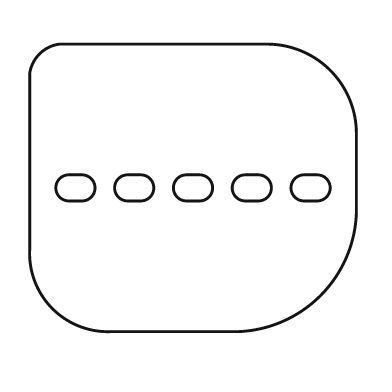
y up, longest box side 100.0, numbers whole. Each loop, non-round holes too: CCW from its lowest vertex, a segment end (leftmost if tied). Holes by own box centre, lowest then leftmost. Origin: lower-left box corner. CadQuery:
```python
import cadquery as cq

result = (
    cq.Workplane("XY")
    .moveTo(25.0, 0.0)
    .lineTo(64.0, 0.0)
    .threePointArc((89.0, 11.0), (100.0, 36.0))
    .lineTo(100.0, 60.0)
    .threePointArc((92.0, 80.0), (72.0, 88.0))
    .lineTo(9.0, 88.0)
    .threePointArc((3.0, 85.0), (0.0, 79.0))
    .lineTo(0.0, 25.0)
    .threePointArc((7.0, 7.0), (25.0, 0.0))
    .close()
    .moveTo(12.0, 40.0)
    .lineTo(16.0, 40.0)
    .threePointArc((20.0, 44.0), (16.0, 48.0))
    .lineTo(12.0, 48.0)
    .threePointArc((8.0, 44.0), (12.0, 40.0))
    .close()
    .moveTo(30.0, 40.0)
    .lineTo(34.0, 40.0)
    .threePointArc((38.0, 44.0), (34.0, 48.0))
    .lineTo(30.0, 48.0)
    .threePointArc((26.0, 44.0), (30.0, 40.0))
    .close()
    .moveTo(48.0, 40.0)
    .lineTo(52.0, 40.0)
    .threePointArc((56.0, 44.0), (52.0, 48.0))
    .lineTo(48.0, 48.0)
    .threePointArc((44.0, 44.0), (48.0, 40.0))
    .close()
    .moveTo(66.0, 40.0)
    .lineTo(70.0, 40.0)
    .threePointArc((74.0, 44.0), (70.0, 48.0))
    .lineTo(66.0, 48.0)
    .threePointArc((62.0, 44.0), (66.0, 40.0))
    .close()
    .moveTo(84.0, 40.0)
    .lineTo(88.0, 40.0)
    .threePointArc((92.0, 44.0), (88.0, 48.0))
    .lineTo(84.0, 48.0)
    .threePointArc((80.0, 44.0), (84.0, 40.0))
    .close()
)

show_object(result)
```